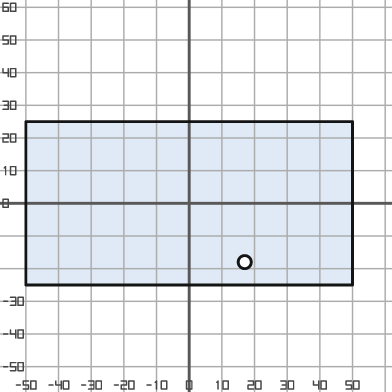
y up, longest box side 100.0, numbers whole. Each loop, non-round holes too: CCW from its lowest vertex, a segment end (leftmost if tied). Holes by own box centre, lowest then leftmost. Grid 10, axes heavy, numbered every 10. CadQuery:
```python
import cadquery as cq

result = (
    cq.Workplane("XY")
    .moveTo(-50.0, -25.0)
    .lineTo(50.0, -25.0)
    .lineTo(50.0, 25.0)
    .lineTo(-50.0, 25.0)
    .close()
    .moveTo(17.0, -18.0)
    .circle(2.0)
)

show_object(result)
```